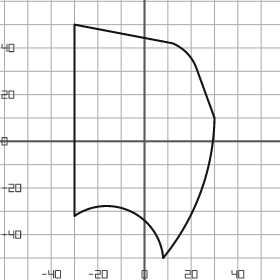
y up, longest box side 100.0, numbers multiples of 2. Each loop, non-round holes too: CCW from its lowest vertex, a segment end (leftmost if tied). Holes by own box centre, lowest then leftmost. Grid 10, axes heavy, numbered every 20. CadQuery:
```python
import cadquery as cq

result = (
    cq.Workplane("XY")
    .moveTo(8.0, -50.0)
    .threePointArc((24.0, -22.0), (30.0, 10.0))
    .lineTo(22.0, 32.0)
    .threePointArc((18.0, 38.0), (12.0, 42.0))
    .lineTo(-30.0, 50.0)
    .lineTo(-30.0, -32.0)
    .threePointArc((-6.0, -30.0), (8.0, -50.0))
    .close()
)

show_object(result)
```